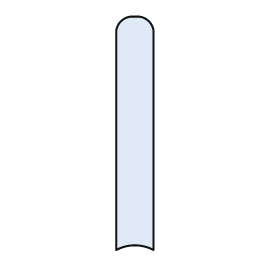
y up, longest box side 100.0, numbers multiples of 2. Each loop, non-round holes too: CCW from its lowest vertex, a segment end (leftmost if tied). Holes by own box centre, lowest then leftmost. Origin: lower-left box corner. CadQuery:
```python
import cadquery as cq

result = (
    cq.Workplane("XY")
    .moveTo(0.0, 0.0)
    .threePointArc((8.0, 2.0), (16.0, 0.0))
    .lineTo(16.0, 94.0)
    .threePointArc((14.0, 98.0), (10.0, 100.0))
    .lineTo(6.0, 100.0)
    .threePointArc((2.0, 98.0), (0.0, 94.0))
    .close()
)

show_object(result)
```